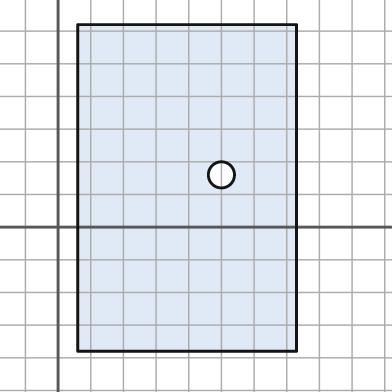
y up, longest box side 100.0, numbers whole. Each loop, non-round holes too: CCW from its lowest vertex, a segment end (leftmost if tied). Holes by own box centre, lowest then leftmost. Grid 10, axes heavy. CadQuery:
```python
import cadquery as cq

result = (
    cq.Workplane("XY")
    .moveTo(6.0, -38.0)
    .lineTo(73.0, -38.0)
    .lineTo(73.0, 62.0)
    .lineTo(6.0, 62.0)
    .close()
    .moveTo(50.0, 16.0)
    .circle(4.0)
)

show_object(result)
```